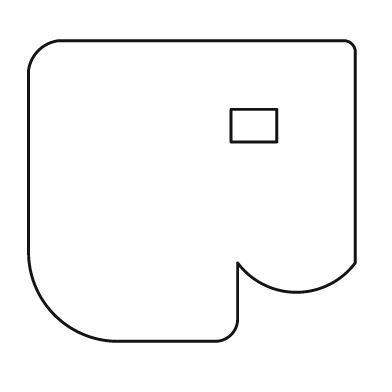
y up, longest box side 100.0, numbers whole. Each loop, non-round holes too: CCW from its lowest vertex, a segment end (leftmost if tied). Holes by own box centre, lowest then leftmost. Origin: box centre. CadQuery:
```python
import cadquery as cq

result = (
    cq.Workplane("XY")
    .moveTo(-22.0, -46.0)
    .lineTo(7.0, -46.0)
    .threePointArc((12.0, -44.0), (14.0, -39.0))
    .lineTo(14.0, -22.0)
    .threePointArc((32.0, -31.0), (50.0, -22.0))
    .lineTo(50.0, 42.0)
    .threePointArc((49.0, 45.0), (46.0, 46.0))
    .lineTo(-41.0, 46.0)
    .threePointArc((-47.0, 43.0), (-50.0, 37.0))
    .lineTo(-50.0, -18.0)
    .threePointArc((-42.0, -38.0), (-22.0, -46.0))
    .close()
    .moveTo(12.0, 15.0)
    .lineTo(26.0, 15.0)
    .lineTo(26.0, 25.0)
    .lineTo(12.0, 25.0)
    .close()
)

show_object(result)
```